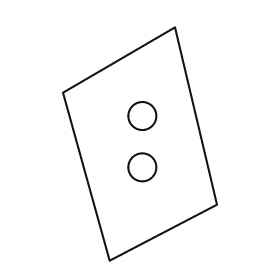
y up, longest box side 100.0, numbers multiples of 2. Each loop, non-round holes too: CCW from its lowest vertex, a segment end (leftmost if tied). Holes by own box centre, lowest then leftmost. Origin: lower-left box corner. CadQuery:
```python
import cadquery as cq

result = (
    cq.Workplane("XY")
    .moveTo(20.0, 0.0)
    .lineTo(66.0, 24.0)
    .lineTo(48.0, 100.0)
    .lineTo(0.0, 72.0)
    .close()
    .moveTo(34.0, 40.0)
    .circle(6.0)
    .moveTo(34.0, 62.0)
    .circle(6.0)
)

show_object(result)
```